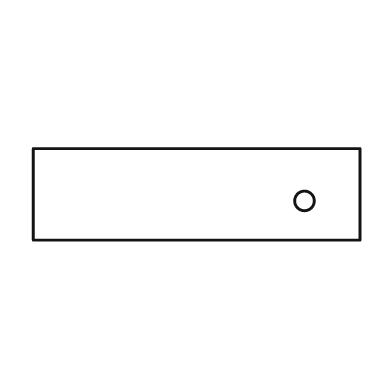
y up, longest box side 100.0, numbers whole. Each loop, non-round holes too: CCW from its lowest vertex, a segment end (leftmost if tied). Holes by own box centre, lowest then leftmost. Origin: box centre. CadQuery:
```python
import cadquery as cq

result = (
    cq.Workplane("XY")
    .moveTo(-50.0, -14.0)
    .lineTo(50.0, -14.0)
    .lineTo(50.0, 14.0)
    .lineTo(-50.0, 14.0)
    .close()
    .moveTo(33.0, -2.0)
    .circle(3.0)
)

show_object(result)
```